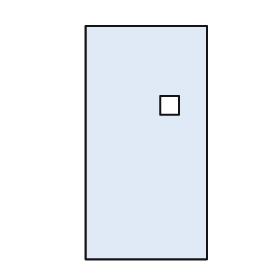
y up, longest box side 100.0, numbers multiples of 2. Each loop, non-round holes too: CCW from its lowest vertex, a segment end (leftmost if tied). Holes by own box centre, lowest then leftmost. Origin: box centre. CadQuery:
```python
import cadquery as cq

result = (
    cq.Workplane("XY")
    .moveTo(-26.0, -50.0)
    .lineTo(26.0, -50.0)
    .lineTo(26.0, 50.0)
    .lineTo(-26.0, 50.0)
    .close()
    .moveTo(6.0, 12.0)
    .lineTo(14.0, 12.0)
    .lineTo(14.0, 20.0)
    .lineTo(6.0, 20.0)
    .close()
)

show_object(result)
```